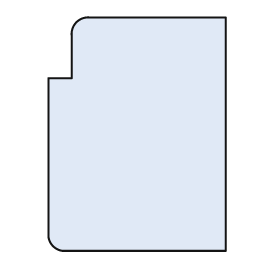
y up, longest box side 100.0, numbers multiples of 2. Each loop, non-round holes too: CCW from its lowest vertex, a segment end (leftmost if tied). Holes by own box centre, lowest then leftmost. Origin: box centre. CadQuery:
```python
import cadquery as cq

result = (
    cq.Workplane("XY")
    .moveTo(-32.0, -50.0)
    .lineTo(38.0, -50.0)
    .lineTo(38.0, 50.0)
    .lineTo(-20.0, 50.0)
    .threePointArc((-26.0, 48.0), (-28.0, 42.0))
    .lineTo(-28.0, 24.0)
    .lineTo(-38.0, 24.0)
    .lineTo(-38.0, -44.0)
    .threePointArc((-36.0, -48.0), (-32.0, -50.0))
    .close()
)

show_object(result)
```